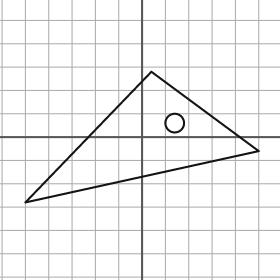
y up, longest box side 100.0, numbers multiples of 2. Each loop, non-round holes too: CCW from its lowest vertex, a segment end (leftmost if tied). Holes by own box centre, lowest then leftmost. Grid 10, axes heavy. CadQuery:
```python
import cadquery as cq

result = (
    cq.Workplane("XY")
    .moveTo(-50.0, -28.0)
    .lineTo(50.0, -6.0)
    .lineTo(4.0, 28.0)
    .close()
    .moveTo(14.0, 6.0)
    .circle(4.0)
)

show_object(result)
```